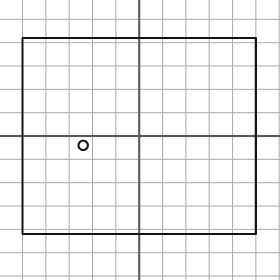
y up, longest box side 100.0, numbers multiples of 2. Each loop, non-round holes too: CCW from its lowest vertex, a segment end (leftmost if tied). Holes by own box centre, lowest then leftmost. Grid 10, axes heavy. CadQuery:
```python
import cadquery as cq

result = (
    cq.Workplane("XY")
    .moveTo(-50.0, -42.0)
    .lineTo(50.0, -42.0)
    .lineTo(50.0, 42.0)
    .lineTo(-50.0, 42.0)
    .close()
    .moveTo(-24.0, -4.0)
    .circle(2.0)
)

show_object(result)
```